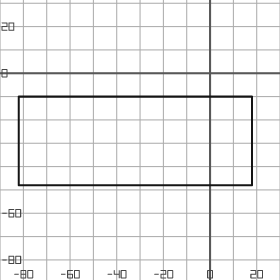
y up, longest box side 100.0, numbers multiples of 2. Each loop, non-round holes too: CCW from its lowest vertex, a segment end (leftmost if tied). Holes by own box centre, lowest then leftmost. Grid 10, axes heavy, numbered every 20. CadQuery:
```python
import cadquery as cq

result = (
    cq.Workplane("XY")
    .moveTo(-82.0, -48.0)
    .lineTo(18.0, -48.0)
    .lineTo(18.0, -10.0)
    .lineTo(-82.0, -10.0)
    .close()
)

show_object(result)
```